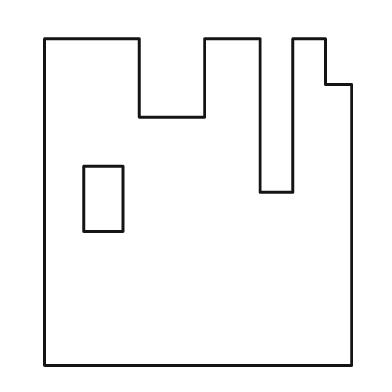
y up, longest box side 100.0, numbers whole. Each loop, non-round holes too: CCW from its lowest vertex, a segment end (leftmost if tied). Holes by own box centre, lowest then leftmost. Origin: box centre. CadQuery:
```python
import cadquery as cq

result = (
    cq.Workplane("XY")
    .moveTo(-47.0, -50.0)
    .lineTo(47.0, -50.0)
    .lineTo(47.0, 36.0)
    .lineTo(39.0, 36.0)
    .lineTo(39.0, 50.0)
    .lineTo(29.0, 50.0)
    .lineTo(29.0, 3.0)
    .lineTo(19.0, 3.0)
    .lineTo(19.0, 50.0)
    .lineTo(2.0, 50.0)
    .lineTo(2.0, 26.0)
    .lineTo(-18.0, 26.0)
    .lineTo(-18.0, 50.0)
    .lineTo(-47.0, 50.0)
    .close()
    .moveTo(-35.0, -9.0)
    .lineTo(-23.0, -9.0)
    .lineTo(-23.0, 11.0)
    .lineTo(-35.0, 11.0)
    .close()
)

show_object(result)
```